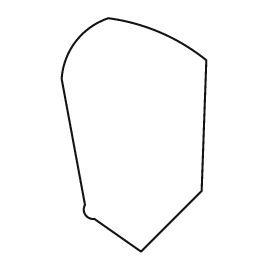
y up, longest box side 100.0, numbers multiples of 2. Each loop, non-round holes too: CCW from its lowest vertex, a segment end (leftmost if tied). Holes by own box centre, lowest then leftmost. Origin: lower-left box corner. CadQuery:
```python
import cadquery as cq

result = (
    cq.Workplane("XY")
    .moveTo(34.0, 0.0)
    .lineTo(60.0, 26.0)
    .lineTo(62.0, 82.0)
    .threePointArc((42.0, 94.0), (20.0, 100.0))
    .threePointArc((6.0, 90.0), (0.0, 74.0))
    .lineTo(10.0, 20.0)
    .threePointArc((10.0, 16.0), (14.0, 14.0))
    .close()
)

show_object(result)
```